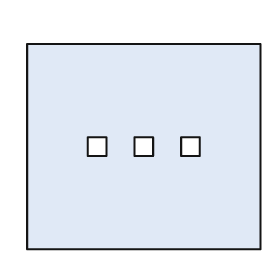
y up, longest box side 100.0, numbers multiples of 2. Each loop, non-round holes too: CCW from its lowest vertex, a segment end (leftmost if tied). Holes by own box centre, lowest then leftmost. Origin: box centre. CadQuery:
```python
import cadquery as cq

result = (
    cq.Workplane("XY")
    .moveTo(-50.0, -44.0)
    .lineTo(50.0, -44.0)
    .lineTo(50.0, 44.0)
    .lineTo(-50.0, 44.0)
    .close()
    .moveTo(-24.0, -4.0)
    .lineTo(-16.0, -4.0)
    .lineTo(-16.0, 4.0)
    .lineTo(-24.0, 4.0)
    .close()
    .moveTo(-4.0, -4.0)
    .lineTo(4.0, -4.0)
    .lineTo(4.0, 4.0)
    .lineTo(-4.0, 4.0)
    .close()
    .moveTo(16.0, -4.0)
    .lineTo(24.0, -4.0)
    .lineTo(24.0, 4.0)
    .lineTo(16.0, 4.0)
    .close()
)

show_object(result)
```